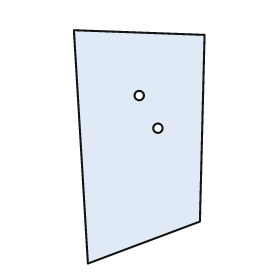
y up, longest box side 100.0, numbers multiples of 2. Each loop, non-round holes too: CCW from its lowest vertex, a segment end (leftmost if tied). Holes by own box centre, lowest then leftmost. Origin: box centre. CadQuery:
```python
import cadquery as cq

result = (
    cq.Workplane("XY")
    .moveTo(-22.0, -50.0)
    .lineTo(26.0, -32.0)
    .lineTo(28.0, 48.0)
    .lineTo(-28.0, 50.0)
    .close()
    .moveTo(8.0, 8.0)
    .circle(2.0)
    .moveTo(0.0, 22.0)
    .circle(2.0)
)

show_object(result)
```